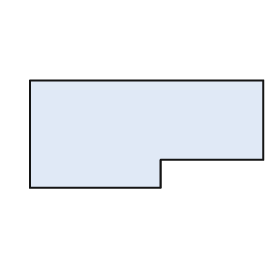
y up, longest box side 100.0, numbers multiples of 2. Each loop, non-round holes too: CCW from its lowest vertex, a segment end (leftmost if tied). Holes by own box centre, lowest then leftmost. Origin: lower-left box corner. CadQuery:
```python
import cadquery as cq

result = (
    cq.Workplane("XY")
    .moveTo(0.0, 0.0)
    .lineTo(56.0, 0.0)
    .lineTo(56.0, 12.0)
    .lineTo(100.0, 12.0)
    .lineTo(100.0, 46.0)
    .lineTo(0.0, 46.0)
    .close()
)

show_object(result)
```